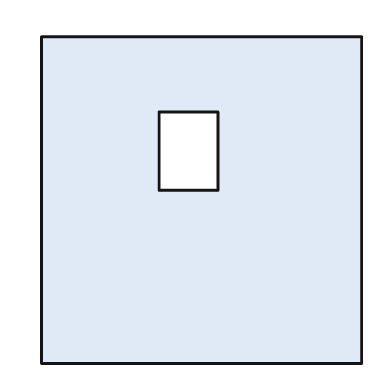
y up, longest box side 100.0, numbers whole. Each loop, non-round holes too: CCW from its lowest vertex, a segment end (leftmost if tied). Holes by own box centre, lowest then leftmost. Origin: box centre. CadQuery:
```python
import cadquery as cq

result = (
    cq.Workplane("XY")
    .moveTo(-49.0, -50.0)
    .lineTo(49.0, -50.0)
    .lineTo(49.0, 50.0)
    .lineTo(-49.0, 50.0)
    .close()
    .moveTo(-13.0, 3.0)
    .lineTo(5.0, 3.0)
    .lineTo(5.0, 27.0)
    .lineTo(-13.0, 27.0)
    .close()
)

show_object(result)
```